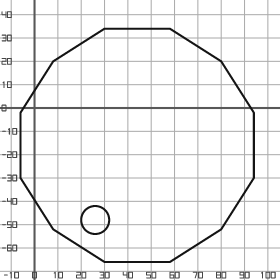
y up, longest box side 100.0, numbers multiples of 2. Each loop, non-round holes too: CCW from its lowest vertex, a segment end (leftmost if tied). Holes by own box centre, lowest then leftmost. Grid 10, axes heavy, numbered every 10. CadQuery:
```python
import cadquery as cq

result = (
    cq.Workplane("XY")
    .moveTo(30.0, -66.0)
    .lineTo(58.0, -66.0)
    .lineTo(80.0, -52.0)
    .lineTo(94.0, -30.0)
    .lineTo(94.0, -2.0)
    .lineTo(80.0, 20.0)
    .lineTo(58.0, 34.0)
    .lineTo(30.0, 34.0)
    .lineTo(8.0, 20.0)
    .lineTo(-6.0, -2.0)
    .lineTo(-6.0, -30.0)
    .lineTo(8.0, -52.0)
    .close()
    .moveTo(26.0, -48.0)
    .circle(6.0)
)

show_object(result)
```